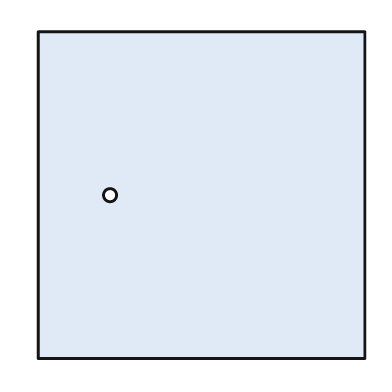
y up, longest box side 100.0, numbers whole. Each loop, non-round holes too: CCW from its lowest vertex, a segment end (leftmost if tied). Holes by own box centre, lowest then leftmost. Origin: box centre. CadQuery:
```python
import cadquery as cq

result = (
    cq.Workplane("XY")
    .moveTo(-50.0, -50.0)
    .lineTo(50.0, -50.0)
    .lineTo(50.0, 50.0)
    .lineTo(-50.0, 50.0)
    .close()
    .moveTo(-28.0, 0.0)
    .circle(2.0)
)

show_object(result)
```